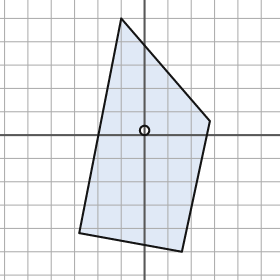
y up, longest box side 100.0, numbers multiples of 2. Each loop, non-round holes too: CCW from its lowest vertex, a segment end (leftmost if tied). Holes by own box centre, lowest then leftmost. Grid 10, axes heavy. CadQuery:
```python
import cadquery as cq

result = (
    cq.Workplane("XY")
    .moveTo(16.0, -50.0)
    .lineTo(28.0, 6.0)
    .lineTo(-10.0, 50.0)
    .lineTo(-28.0, -42.0)
    .close()
    .moveTo(0.0, 2.0)
    .circle(2.0)
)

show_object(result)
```